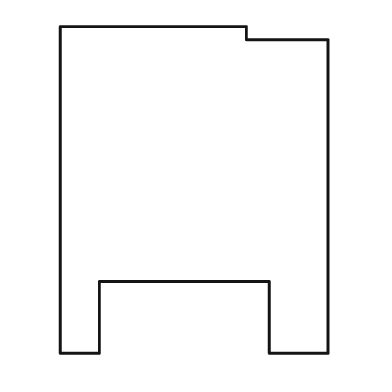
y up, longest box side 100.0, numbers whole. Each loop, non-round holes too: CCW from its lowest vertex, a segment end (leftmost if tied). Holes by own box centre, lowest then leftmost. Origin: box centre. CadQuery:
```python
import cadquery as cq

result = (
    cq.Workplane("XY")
    .moveTo(-41.0, -50.0)
    .lineTo(-29.0, -50.0)
    .lineTo(-29.0, -28.0)
    .lineTo(23.0, -28.0)
    .lineTo(23.0, -50.0)
    .lineTo(41.0, -50.0)
    .lineTo(41.0, 46.0)
    .lineTo(16.0, 46.0)
    .lineTo(16.0, 50.0)
    .lineTo(-41.0, 50.0)
    .close()
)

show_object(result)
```